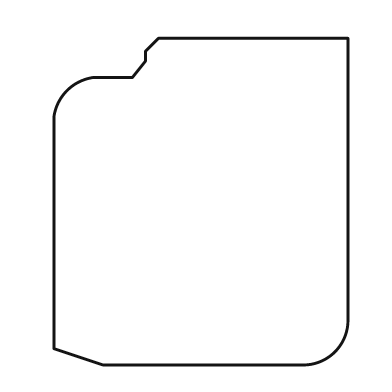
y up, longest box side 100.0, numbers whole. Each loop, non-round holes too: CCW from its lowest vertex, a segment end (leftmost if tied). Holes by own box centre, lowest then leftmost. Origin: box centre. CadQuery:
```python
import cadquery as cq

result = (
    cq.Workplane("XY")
    .moveTo(-30.0, -50.0)
    .lineTo(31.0, -50.0)
    .threePointArc((41.0, -46.0), (45.0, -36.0))
    .lineTo(45.0, 50.0)
    .lineTo(-13.0, 50.0)
    .lineTo(-17.0, 46.0)
    .lineTo(-17.0, 43.0)
    .lineTo(-21.0, 38.0)
    .lineTo(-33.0, 38.0)
    .threePointArc((-41.0, 34.0), (-45.0, 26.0))
    .lineTo(-45.0, -45.0)
    .close()
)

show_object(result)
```